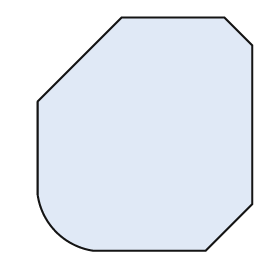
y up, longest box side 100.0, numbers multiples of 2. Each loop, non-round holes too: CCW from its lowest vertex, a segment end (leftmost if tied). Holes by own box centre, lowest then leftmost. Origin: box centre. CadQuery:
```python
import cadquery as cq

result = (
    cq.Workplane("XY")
    .moveTo(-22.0, -50.0)
    .lineTo(26.0, -50.0)
    .lineTo(46.0, -30.0)
    .lineTo(46.0, 38.0)
    .lineTo(34.0, 50.0)
    .lineTo(-10.0, 50.0)
    .lineTo(-46.0, 14.0)
    .lineTo(-46.0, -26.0)
    .threePointArc((-38.0, -42.0), (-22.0, -50.0))
    .close()
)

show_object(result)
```